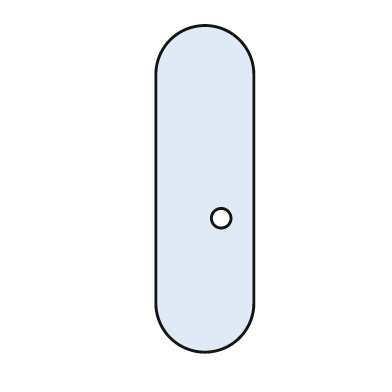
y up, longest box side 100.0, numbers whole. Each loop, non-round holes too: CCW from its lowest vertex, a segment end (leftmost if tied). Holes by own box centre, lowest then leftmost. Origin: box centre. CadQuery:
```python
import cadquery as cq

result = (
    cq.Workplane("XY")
    .moveTo(-15.0, -35.0)
    .threePointArc((0.0, -50.0), (15.0, -35.0))
    .lineTo(15.0, 35.0)
    .threePointArc((0.0, 50.0), (-15.0, 35.0))
    .close()
    .moveTo(5.0, -9.0)
    .circle(3.0)
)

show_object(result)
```